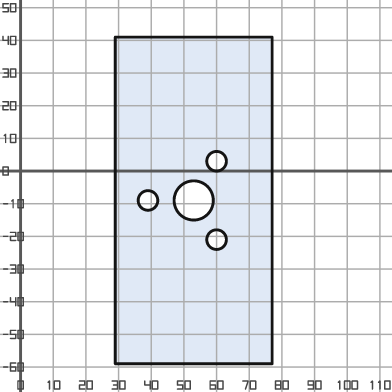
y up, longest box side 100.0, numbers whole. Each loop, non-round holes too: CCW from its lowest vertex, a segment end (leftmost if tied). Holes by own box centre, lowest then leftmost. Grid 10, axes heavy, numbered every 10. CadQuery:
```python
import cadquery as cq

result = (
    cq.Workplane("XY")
    .moveTo(29.0, -59.0)
    .lineTo(77.0, -59.0)
    .lineTo(77.0, 41.0)
    .lineTo(29.0, 41.0)
    .close()
    .moveTo(60.0, -21.0)
    .circle(3.0)
    .moveTo(39.0, -9.0)
    .circle(3.0)
    .moveTo(53.0, -9.0)
    .circle(6.0)
    .moveTo(60.0, 3.0)
    .circle(3.0)
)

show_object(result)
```